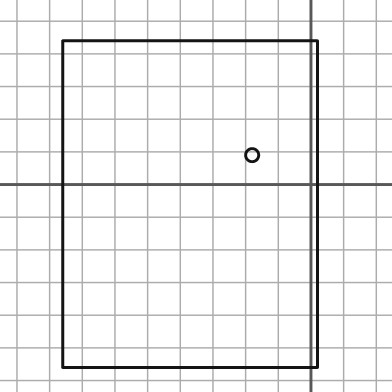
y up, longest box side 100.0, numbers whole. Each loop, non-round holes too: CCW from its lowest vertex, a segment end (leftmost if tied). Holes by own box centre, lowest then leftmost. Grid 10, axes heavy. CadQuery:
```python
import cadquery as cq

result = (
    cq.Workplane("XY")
    .moveTo(-76.0, -56.0)
    .lineTo(2.0, -56.0)
    .lineTo(2.0, 44.0)
    .lineTo(-76.0, 44.0)
    .close()
    .moveTo(-18.0, 9.0)
    .circle(2.0)
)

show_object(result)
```